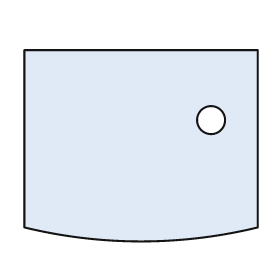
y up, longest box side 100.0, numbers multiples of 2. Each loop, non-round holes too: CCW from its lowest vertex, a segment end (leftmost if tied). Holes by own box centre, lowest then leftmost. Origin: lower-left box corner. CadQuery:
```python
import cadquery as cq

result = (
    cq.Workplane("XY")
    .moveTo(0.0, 6.0)
    .threePointArc((50.0, 0.0), (100.0, 6.0))
    .lineTo(100.0, 82.0)
    .lineTo(0.0, 82.0)
    .close()
    .moveTo(80.0, 52.0)
    .circle(6.0)
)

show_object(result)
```